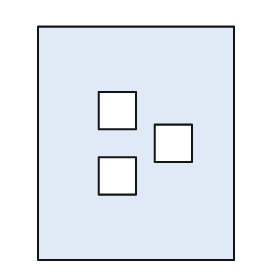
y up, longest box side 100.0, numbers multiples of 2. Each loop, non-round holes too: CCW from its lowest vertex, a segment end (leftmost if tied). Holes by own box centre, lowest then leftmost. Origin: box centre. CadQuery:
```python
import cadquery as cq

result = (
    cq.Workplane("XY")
    .moveTo(-42.0, -50.0)
    .lineTo(42.0, -50.0)
    .lineTo(42.0, 50.0)
    .lineTo(-42.0, 50.0)
    .close()
    .moveTo(-16.0, -22.0)
    .lineTo(0.0, -22.0)
    .lineTo(0.0, -6.0)
    .lineTo(-16.0, -6.0)
    .close()
    .moveTo(8.0, -8.0)
    .lineTo(24.0, -8.0)
    .lineTo(24.0, 8.0)
    .lineTo(8.0, 8.0)
    .close()
    .moveTo(-16.0, 6.0)
    .lineTo(0.0, 6.0)
    .lineTo(0.0, 22.0)
    .lineTo(-16.0, 22.0)
    .close()
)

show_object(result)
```